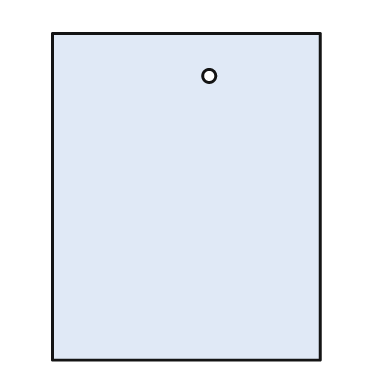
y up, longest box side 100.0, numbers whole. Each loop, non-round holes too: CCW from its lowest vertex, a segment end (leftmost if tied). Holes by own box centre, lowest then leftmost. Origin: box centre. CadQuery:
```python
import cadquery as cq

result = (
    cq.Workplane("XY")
    .moveTo(-41.0, -50.0)
    .lineTo(41.0, -50.0)
    .lineTo(41.0, 50.0)
    .lineTo(-41.0, 50.0)
    .close()
    .moveTo(7.0, 37.0)
    .circle(2.0)
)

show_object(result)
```